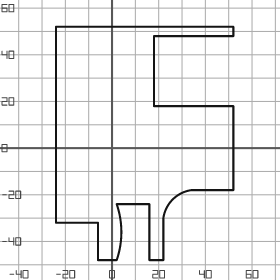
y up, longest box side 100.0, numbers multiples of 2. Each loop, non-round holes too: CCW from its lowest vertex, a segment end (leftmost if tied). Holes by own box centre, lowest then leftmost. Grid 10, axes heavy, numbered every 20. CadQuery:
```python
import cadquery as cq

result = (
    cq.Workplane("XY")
    .moveTo(-6.0, -48.0)
    .lineTo(2.0, -48.0)
    .threePointArc((4.0, -36.0), (2.0, -24.0))
    .lineTo(16.0, -24.0)
    .lineTo(16.0, -48.0)
    .lineTo(22.0, -48.0)
    .lineTo(22.0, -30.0)
    .threePointArc((26.0, -22.0), (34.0, -18.0))
    .lineTo(52.0, -18.0)
    .lineTo(52.0, 18.0)
    .lineTo(18.0, 18.0)
    .lineTo(18.0, 48.0)
    .lineTo(52.0, 48.0)
    .lineTo(52.0, 52.0)
    .lineTo(-24.0, 52.0)
    .lineTo(-24.0, -32.0)
    .lineTo(-6.0, -32.0)
    .close()
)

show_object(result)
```